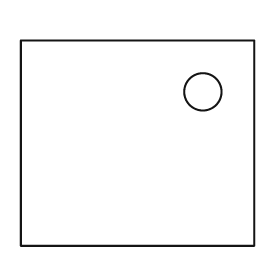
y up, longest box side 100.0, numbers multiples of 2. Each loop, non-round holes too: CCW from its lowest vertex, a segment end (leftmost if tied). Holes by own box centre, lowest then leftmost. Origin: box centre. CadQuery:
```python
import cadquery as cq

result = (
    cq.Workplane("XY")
    .moveTo(-50.0, -44.0)
    .lineTo(50.0, -44.0)
    .lineTo(50.0, 44.0)
    .lineTo(-50.0, 44.0)
    .close()
    .moveTo(28.0, 22.0)
    .circle(8.0)
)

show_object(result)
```